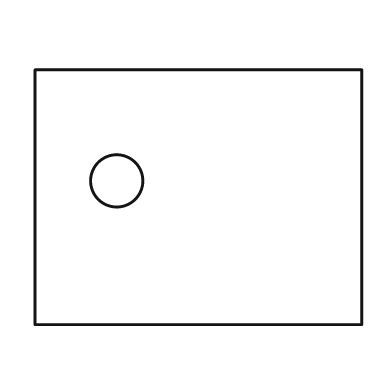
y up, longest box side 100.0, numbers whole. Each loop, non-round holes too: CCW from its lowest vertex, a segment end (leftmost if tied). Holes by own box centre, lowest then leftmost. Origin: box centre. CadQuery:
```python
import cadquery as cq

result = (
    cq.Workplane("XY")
    .moveTo(-50.0, -39.0)
    .lineTo(50.0, -39.0)
    .lineTo(50.0, 39.0)
    .lineTo(-50.0, 39.0)
    .close()
    .moveTo(-25.0, 5.0)
    .circle(8.0)
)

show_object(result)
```